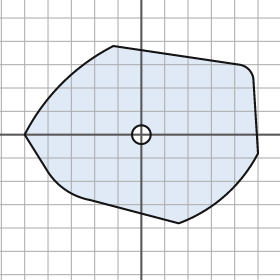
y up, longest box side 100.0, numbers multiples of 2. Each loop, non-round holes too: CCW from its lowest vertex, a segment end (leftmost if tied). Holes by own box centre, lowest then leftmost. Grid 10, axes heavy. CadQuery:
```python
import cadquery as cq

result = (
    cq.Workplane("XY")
    .moveTo(16.0, -38.0)
    .threePointArc((36.0, -26.0), (50.0, -8.0))
    .lineTo(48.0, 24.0)
    .threePointArc((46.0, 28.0), (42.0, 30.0))
    .lineTo(-12.0, 38.0)
    .threePointArc((-34.0, 22.0), (-50.0, 0.0))
    .lineTo(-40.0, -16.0)
    .threePointArc((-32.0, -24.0), (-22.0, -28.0))
    .close()
    .moveTo(0.0, 0.0)
    .circle(4.0)
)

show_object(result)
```